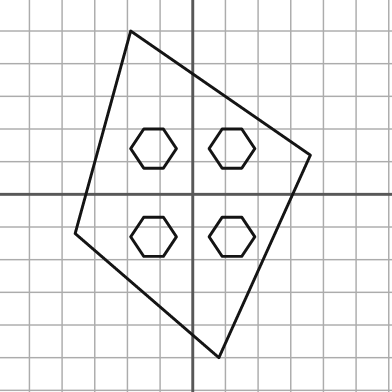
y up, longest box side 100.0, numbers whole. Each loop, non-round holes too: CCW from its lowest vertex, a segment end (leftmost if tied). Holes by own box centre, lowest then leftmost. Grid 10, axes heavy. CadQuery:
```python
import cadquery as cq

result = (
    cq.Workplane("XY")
    .moveTo(8.0, -50.0)
    .lineTo(36.0, 12.0)
    .lineTo(-19.0, 50.0)
    .lineTo(-36.0, -12.0)
    .close()
    .moveTo(-15.0, -19.0)
    .lineTo(-9.0, -19.0)
    .lineTo(-5.0, -13.0)
    .lineTo(-9.0, -7.0)
    .lineTo(-15.0, -7.0)
    .lineTo(-19.0, -13.0)
    .close()
    .moveTo(9.0, -19.0)
    .lineTo(15.0, -19.0)
    .lineTo(19.0, -13.0)
    .lineTo(15.0, -7.0)
    .lineTo(9.0, -7.0)
    .lineTo(5.0, -13.0)
    .close()
    .moveTo(-15.0, 8.0)
    .lineTo(-9.0, 8.0)
    .lineTo(-5.0, 14.0)
    .lineTo(-9.0, 20.0)
    .lineTo(-15.0, 20.0)
    .lineTo(-19.0, 14.0)
    .close()
    .moveTo(9.0, 8.0)
    .lineTo(15.0, 8.0)
    .lineTo(19.0, 14.0)
    .lineTo(15.0, 20.0)
    .lineTo(9.0, 20.0)
    .lineTo(5.0, 14.0)
    .close()
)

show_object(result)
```